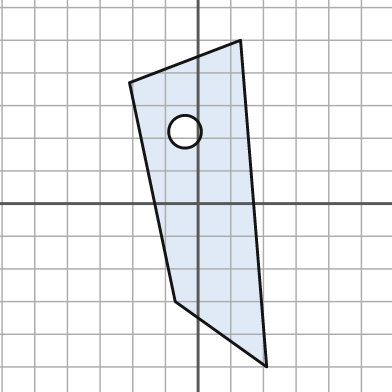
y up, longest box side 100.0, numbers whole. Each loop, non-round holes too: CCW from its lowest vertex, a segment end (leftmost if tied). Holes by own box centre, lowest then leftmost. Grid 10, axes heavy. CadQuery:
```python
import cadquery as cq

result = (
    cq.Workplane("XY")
    .moveTo(21.0, -50.0)
    .lineTo(13.0, 50.0)
    .lineTo(-21.0, 37.0)
    .lineTo(-7.0, -30.0)
    .close()
    .moveTo(-4.0, 22.0)
    .circle(5.0)
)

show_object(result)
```